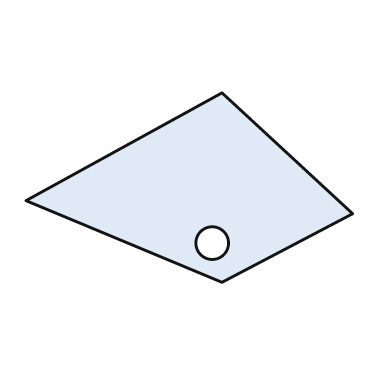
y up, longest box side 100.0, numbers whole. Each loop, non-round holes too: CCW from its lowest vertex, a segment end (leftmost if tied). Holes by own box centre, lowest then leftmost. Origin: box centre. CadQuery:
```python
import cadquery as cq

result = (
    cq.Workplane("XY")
    .moveTo(10.0, -29.0)
    .lineTo(50.0, -8.0)
    .lineTo(10.0, 29.0)
    .lineTo(-50.0, -4.0)
    .close()
    .moveTo(7.0, -17.0)
    .circle(5.0)
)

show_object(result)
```